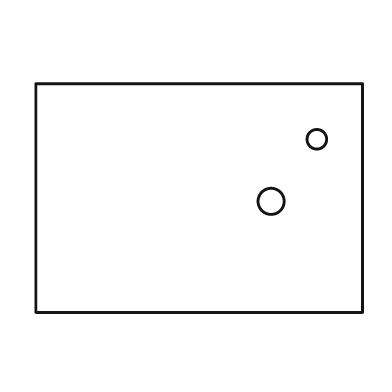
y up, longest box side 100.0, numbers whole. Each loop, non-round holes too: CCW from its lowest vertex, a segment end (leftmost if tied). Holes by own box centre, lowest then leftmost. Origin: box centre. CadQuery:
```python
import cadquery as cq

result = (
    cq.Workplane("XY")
    .moveTo(-50.0, -35.0)
    .lineTo(50.0, -35.0)
    .lineTo(50.0, 35.0)
    .lineTo(-50.0, 35.0)
    .close()
    .moveTo(22.0, -1.0)
    .circle(4.0)
    .moveTo(36.0, 18.0)
    .circle(3.0)
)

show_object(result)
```